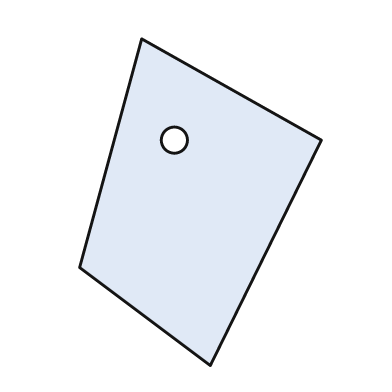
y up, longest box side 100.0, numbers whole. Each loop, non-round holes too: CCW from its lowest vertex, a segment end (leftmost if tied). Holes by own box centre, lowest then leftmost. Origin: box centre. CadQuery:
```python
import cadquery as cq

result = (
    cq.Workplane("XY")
    .moveTo(3.0, -50.0)
    .lineTo(37.0, 19.0)
    .lineTo(-18.0, 50.0)
    .lineTo(-37.0, -20.0)
    .close()
    .moveTo(-8.0, 19.0)
    .circle(4.0)
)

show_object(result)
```